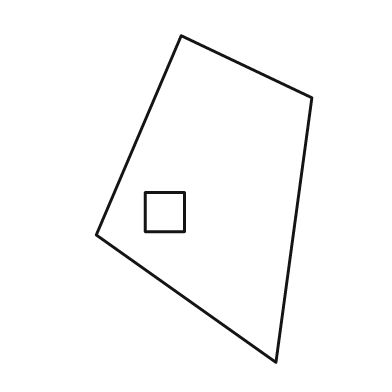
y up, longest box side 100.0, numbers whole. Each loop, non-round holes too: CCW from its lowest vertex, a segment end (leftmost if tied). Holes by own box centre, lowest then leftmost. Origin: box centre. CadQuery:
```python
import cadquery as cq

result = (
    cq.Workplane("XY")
    .moveTo(22.0, -50.0)
    .lineTo(33.0, 31.0)
    .lineTo(-7.0, 50.0)
    .lineTo(-33.0, -11.0)
    .close()
    .moveTo(-18.0, -10.0)
    .lineTo(-6.0, -10.0)
    .lineTo(-6.0, 2.0)
    .lineTo(-18.0, 2.0)
    .close()
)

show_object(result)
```